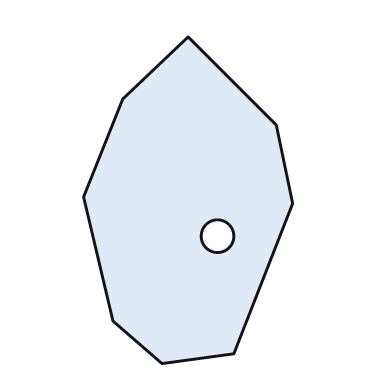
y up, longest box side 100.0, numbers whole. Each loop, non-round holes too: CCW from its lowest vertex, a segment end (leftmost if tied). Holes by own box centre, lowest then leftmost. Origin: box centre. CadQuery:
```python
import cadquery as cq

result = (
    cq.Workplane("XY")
    .moveTo(-8.0, -50.0)
    .lineTo(14.0, -47.0)
    .lineTo(32.0, -1.0)
    .lineTo(27.0, 23.0)
    .lineTo(0.0, 50.0)
    .lineTo(-20.0, 31.0)
    .lineTo(-32.0, 1.0)
    .lineTo(-23.0, -37.0)
    .close()
    .moveTo(9.0, -11.0)
    .circle(5.0)
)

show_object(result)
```